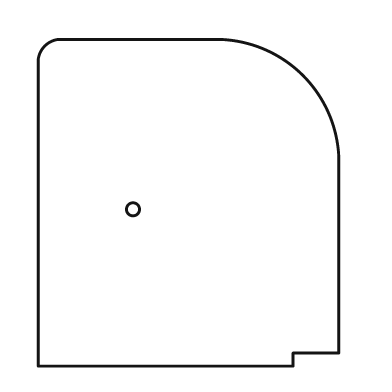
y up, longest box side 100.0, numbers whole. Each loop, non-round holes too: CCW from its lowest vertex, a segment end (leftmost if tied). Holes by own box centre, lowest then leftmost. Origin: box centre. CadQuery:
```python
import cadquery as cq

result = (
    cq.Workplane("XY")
    .moveTo(-46.0, -50.0)
    .lineTo(32.0, -50.0)
    .lineTo(32.0, -46.0)
    .lineTo(46.0, -46.0)
    .lineTo(46.0, 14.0)
    .threePointArc((35.0, 39.0), (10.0, 50.0))
    .lineTo(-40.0, 50.0)
    .threePointArc((-44.0, 48.0), (-46.0, 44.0))
    .close()
    .moveTo(-17.0, -2.0)
    .circle(2.0)
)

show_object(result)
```